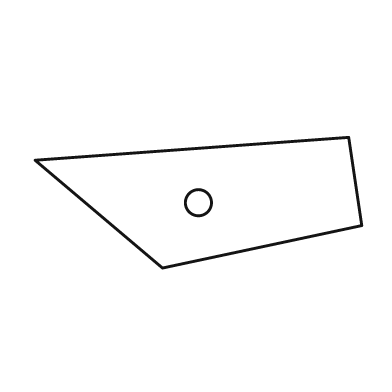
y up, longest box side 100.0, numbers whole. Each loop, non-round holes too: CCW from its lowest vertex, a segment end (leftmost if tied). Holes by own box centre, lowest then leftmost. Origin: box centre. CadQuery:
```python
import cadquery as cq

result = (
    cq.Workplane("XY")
    .moveTo(-11.0, -20.0)
    .lineTo(50.0, -7.0)
    .lineTo(46.0, 20.0)
    .lineTo(-50.0, 13.0)
    .close()
    .moveTo(0.0, 0.0)
    .circle(4.0)
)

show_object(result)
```